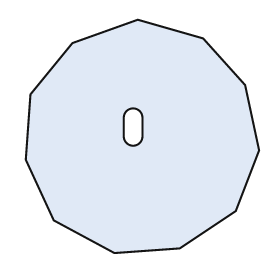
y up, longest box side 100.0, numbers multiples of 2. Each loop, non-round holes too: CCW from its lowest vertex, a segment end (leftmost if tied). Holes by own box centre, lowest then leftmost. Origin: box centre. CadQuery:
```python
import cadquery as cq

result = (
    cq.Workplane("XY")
    .moveTo(-12.0, -50.0)
    .lineTo(16.0, -48.0)
    .lineTo(40.0, -32.0)
    .lineTo(50.0, -6.0)
    .lineTo(44.0, 22.0)
    .lineTo(26.0, 42.0)
    .lineTo(-2.0, 50.0)
    .lineTo(-30.0, 40.0)
    .lineTo(-48.0, 18.0)
    .lineTo(-50.0, -10.0)
    .lineTo(-38.0, -36.0)
    .close()
    .moveTo(-8.0, 0.0)
    .threePointArc((-4.0, -4.0), (0.0, 0.0))
    .lineTo(0.0, 8.0)
    .threePointArc((-4.0, 12.0), (-8.0, 8.0))
    .close()
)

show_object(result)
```